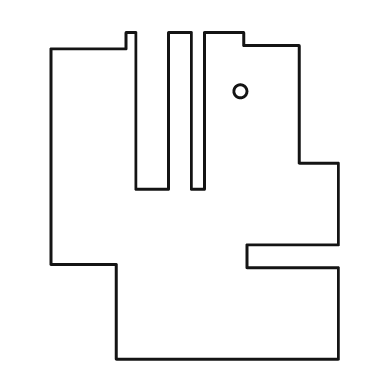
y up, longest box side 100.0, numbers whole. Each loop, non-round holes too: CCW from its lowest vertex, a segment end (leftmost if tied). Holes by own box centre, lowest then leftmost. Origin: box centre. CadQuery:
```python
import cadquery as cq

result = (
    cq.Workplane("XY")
    .moveTo(-24.0, -50.0)
    .lineTo(44.0, -50.0)
    .lineTo(44.0, -22.0)
    .lineTo(16.0, -22.0)
    .lineTo(16.0, -15.0)
    .lineTo(44.0, -15.0)
    .lineTo(44.0, 10.0)
    .lineTo(32.0, 10.0)
    .lineTo(32.0, 46.0)
    .lineTo(15.0, 46.0)
    .lineTo(15.0, 50.0)
    .lineTo(3.0, 50.0)
    .lineTo(3.0, 2.0)
    .lineTo(-1.0, 2.0)
    .lineTo(-1.0, 50.0)
    .lineTo(-8.0, 50.0)
    .lineTo(-8.0, 2.0)
    .lineTo(-18.0, 2.0)
    .lineTo(-18.0, 50.0)
    .lineTo(-21.0, 50.0)
    .lineTo(-21.0, 45.0)
    .lineTo(-44.0, 45.0)
    .lineTo(-44.0, -21.0)
    .lineTo(-24.0, -21.0)
    .close()
    .moveTo(14.0, 32.0)
    .circle(2.0)
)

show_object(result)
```